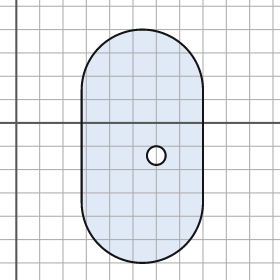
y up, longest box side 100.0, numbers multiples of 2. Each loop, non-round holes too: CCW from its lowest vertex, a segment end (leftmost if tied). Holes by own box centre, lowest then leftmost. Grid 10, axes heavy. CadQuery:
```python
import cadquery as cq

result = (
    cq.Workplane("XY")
    .moveTo(28.0, -34.0)
    .threePointArc((54.0, -60.0), (80.0, -34.0))
    .lineTo(80.0, 14.0)
    .threePointArc((54.0, 40.0), (28.0, 14.0))
    .close()
    .moveTo(60.0, -14.0)
    .circle(4.0)
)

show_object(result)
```